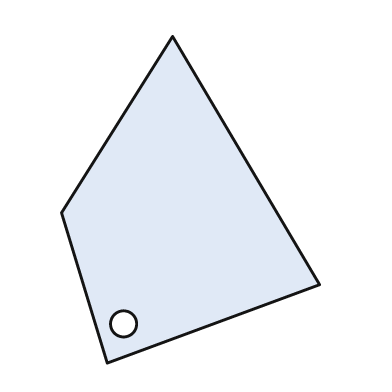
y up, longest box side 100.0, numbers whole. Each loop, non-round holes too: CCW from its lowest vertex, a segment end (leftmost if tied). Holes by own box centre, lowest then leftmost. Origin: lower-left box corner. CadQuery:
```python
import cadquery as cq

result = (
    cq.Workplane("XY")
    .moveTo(14.0, 0.0)
    .lineTo(79.0, 24.0)
    .lineTo(34.0, 100.0)
    .lineTo(0.0, 46.0)
    .close()
    .moveTo(19.0, 12.0)
    .circle(4.0)
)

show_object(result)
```